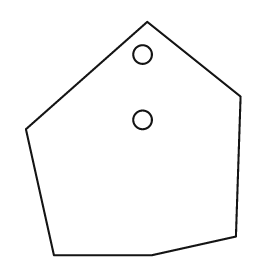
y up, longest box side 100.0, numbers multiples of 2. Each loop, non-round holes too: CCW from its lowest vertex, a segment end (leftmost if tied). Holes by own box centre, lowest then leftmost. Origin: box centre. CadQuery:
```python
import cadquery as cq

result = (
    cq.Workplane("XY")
    .moveTo(-34.0, -50.0)
    .lineTo(8.0, -50.0)
    .lineTo(44.0, -42.0)
    .lineTo(46.0, 18.0)
    .lineTo(6.0, 50.0)
    .lineTo(-46.0, 4.0)
    .close()
    .moveTo(4.0, 8.0)
    .circle(4.0)
    .moveTo(4.0, 36.0)
    .circle(4.0)
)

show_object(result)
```